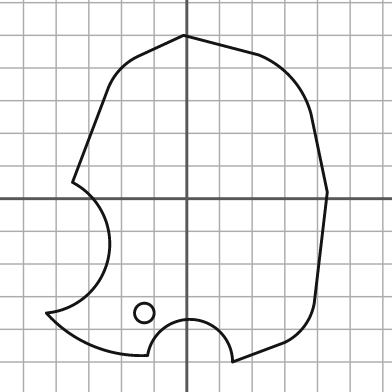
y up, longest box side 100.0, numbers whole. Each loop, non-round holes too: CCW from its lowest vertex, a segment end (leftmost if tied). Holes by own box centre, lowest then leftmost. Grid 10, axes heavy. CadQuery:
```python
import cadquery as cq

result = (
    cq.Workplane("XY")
    .moveTo(14.0, -50.0)
    .lineTo(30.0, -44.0)
    .threePointArc((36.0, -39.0), (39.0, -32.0))
    .lineTo(43.0, 2.0)
    .lineTo(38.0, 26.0)
    .threePointArc((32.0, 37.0), (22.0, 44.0))
    .lineTo(-1.0, 50.0)
    .lineTo(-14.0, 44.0)
    .threePointArc((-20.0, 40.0), (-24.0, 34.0))
    .lineTo(-35.0, 5.0)
    .threePointArc((-24.0, -18.0), (-43.0, -35.0))
    .threePointArc((-29.0, -45.0), (-12.0, -48.0))
    .threePointArc((2.0, -37.0), (14.0, -50.0))
    .close()
    .moveTo(-13.0, -35.0)
    .circle(3.0)
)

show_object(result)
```